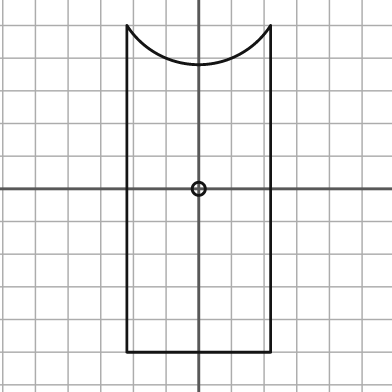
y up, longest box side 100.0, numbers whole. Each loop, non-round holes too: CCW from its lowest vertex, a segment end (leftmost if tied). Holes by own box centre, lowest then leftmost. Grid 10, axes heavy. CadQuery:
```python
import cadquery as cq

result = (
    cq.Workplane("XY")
    .moveTo(-22.0, -50.0)
    .lineTo(22.0, -50.0)
    .lineTo(22.0, 50.0)
    .threePointArc((0.0, 38.0), (-22.0, 50.0))
    .close()
    .moveTo(0.0, 0.0)
    .circle(2.0)
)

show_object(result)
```